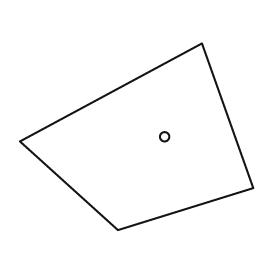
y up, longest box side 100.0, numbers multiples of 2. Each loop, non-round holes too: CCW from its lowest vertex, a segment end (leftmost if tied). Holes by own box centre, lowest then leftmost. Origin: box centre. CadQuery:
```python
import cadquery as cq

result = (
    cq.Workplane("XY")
    .moveTo(-8.0, -40.0)
    .lineTo(50.0, -22.0)
    .lineTo(28.0, 40.0)
    .lineTo(-50.0, -2.0)
    .close()
    .moveTo(12.0, 0.0)
    .circle(2.0)
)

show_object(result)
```